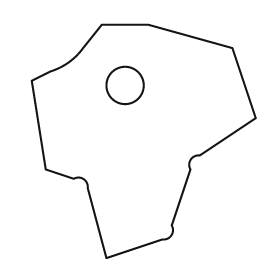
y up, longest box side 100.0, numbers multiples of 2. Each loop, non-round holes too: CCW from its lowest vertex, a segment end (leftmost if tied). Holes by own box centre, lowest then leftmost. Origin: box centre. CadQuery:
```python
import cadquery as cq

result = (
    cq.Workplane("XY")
    .moveTo(-16.0, -50.0)
    .lineTo(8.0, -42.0)
    .threePointArc((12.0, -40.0), (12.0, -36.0))
    .lineTo(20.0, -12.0)
    .threePointArc((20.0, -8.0), (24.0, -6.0))
    .lineTo(48.0, 10.0)
    .lineTo(38.0, 40.0)
    .lineTo(2.0, 50.0)
    .lineTo(-18.0, 50.0)
    .lineTo(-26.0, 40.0)
    .threePointArc((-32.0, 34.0), (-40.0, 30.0))
    .lineTo(-48.0, 26.0)
    .lineTo(-42.0, -12.0)
    .lineTo(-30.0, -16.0)
    .threePointArc((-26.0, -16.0), (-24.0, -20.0))
    .close()
    .moveTo(-8.0, 24.0)
    .circle(8.0)
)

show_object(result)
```